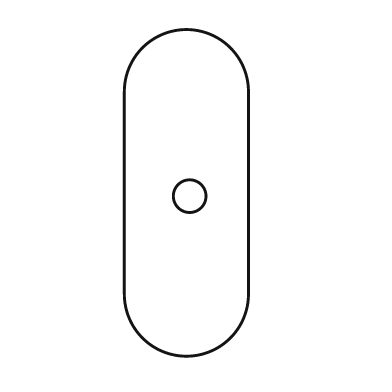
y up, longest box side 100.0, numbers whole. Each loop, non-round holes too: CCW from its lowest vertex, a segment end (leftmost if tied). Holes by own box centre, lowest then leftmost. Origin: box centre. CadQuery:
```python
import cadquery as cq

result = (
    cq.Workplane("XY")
    .moveTo(-19.0, -31.0)
    .threePointArc((0.0, -50.0), (19.0, -31.0))
    .lineTo(19.0, 31.0)
    .threePointArc((0.0, 50.0), (-19.0, 31.0))
    .close()
    .moveTo(1.0, -1.0)
    .circle(5.0)
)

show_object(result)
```